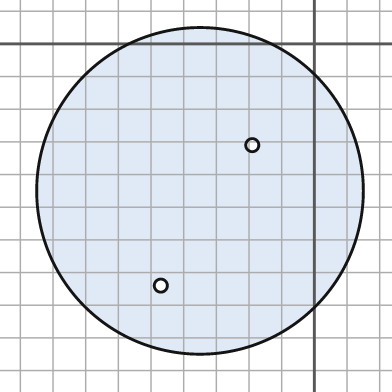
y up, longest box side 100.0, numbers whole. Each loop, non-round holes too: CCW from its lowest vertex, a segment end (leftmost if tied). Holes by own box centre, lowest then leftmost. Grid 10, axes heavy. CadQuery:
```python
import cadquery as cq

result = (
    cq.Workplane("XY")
    .moveTo(-35.0, -45.0)
    .circle(50.0)
    .moveTo(-47.0, -74.0)
    .circle(2.0)
    .moveTo(-19.0, -31.0)
    .circle(2.0)
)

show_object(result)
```